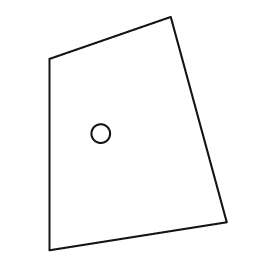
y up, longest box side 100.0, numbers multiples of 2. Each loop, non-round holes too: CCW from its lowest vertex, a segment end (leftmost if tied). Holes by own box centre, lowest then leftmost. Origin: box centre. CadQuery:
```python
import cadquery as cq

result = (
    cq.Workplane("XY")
    .moveTo(-38.0, -50.0)
    .lineTo(38.0, -38.0)
    .lineTo(14.0, 50.0)
    .lineTo(-38.0, 32.0)
    .close()
    .moveTo(-16.0, 0.0)
    .circle(4.0)
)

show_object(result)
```